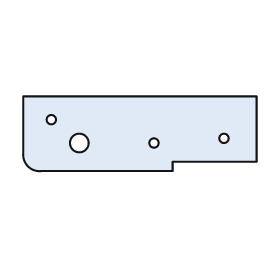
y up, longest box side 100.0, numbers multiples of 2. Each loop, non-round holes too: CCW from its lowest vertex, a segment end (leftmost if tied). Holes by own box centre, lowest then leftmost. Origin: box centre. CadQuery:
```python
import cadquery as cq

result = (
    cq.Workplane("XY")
    .moveTo(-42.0, -16.0)
    .lineTo(14.0, -16.0)
    .lineTo(14.0, -12.0)
    .lineTo(50.0, -12.0)
    .lineTo(50.0, 16.0)
    .lineTo(-50.0, 16.0)
    .lineTo(-50.0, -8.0)
    .threePointArc((-48.0, -14.0), (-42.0, -16.0))
    .close()
    .moveTo(-26.0, -4.0)
    .circle(4.0)
    .moveTo(6.0, -4.0)
    .circle(2.0)
    .moveTo(36.0, -2.0)
    .circle(2.0)
    .moveTo(-38.0, 6.0)
    .circle(2.0)
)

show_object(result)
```